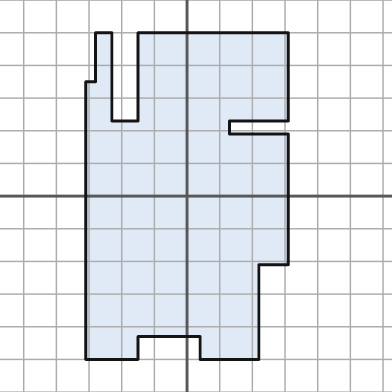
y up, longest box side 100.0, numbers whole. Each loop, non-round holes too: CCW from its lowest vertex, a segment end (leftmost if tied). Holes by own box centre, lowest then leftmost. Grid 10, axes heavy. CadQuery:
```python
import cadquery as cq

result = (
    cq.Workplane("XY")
    .moveTo(-31.0, -50.0)
    .lineTo(-15.0, -50.0)
    .lineTo(-15.0, -43.0)
    .lineTo(4.0, -43.0)
    .lineTo(4.0, -50.0)
    .lineTo(22.0, -50.0)
    .lineTo(22.0, -21.0)
    .lineTo(31.0, -21.0)
    .lineTo(31.0, 19.0)
    .lineTo(13.0, 19.0)
    .lineTo(13.0, 23.0)
    .lineTo(31.0, 23.0)
    .lineTo(31.0, 50.0)
    .lineTo(-15.0, 50.0)
    .lineTo(-15.0, 23.0)
    .lineTo(-23.0, 23.0)
    .lineTo(-23.0, 50.0)
    .lineTo(-28.0, 50.0)
    .lineTo(-28.0, 35.0)
    .lineTo(-31.0, 35.0)
    .close()
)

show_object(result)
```